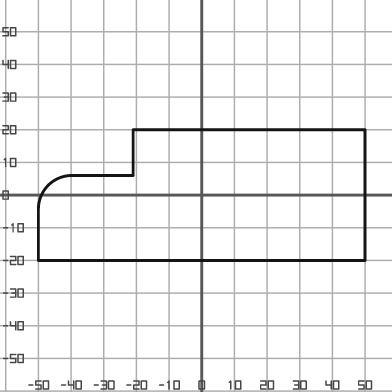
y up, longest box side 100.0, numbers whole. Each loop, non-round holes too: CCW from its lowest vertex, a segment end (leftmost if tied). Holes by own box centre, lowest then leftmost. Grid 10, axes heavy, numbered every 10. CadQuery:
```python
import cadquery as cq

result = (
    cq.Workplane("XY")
    .moveTo(-50.0, -20.0)
    .lineTo(50.0, -20.0)
    .lineTo(50.0, 20.0)
    .lineTo(-21.0, 20.0)
    .lineTo(-21.0, 6.0)
    .lineTo(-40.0, 6.0)
    .threePointArc((-47.0, 3.0), (-50.0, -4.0))
    .close()
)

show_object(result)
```